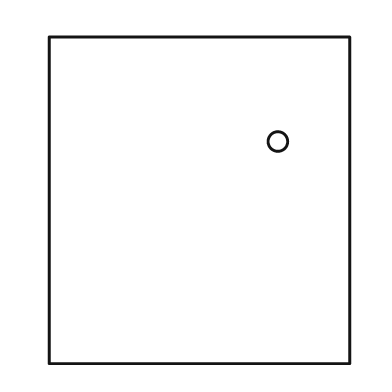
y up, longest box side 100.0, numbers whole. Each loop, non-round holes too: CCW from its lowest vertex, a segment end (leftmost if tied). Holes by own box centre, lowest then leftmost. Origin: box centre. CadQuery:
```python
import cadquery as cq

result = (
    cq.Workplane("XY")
    .moveTo(-46.0, -50.0)
    .lineTo(46.0, -50.0)
    .lineTo(46.0, 50.0)
    .lineTo(-46.0, 50.0)
    .close()
    .moveTo(24.0, 18.0)
    .circle(3.0)
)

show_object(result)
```